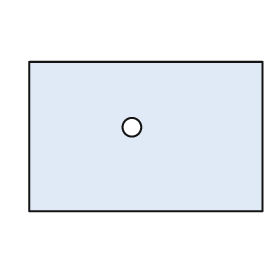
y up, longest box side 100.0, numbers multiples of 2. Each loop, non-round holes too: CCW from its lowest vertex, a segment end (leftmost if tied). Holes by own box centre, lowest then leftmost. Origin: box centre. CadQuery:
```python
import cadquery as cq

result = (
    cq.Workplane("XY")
    .moveTo(-50.0, -32.0)
    .lineTo(50.0, -32.0)
    .lineTo(50.0, 32.0)
    .lineTo(-50.0, 32.0)
    .close()
    .moveTo(-6.0, 4.0)
    .circle(4.0)
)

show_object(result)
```